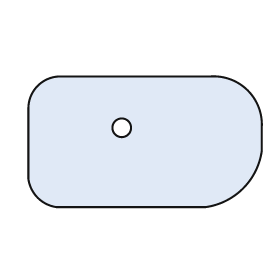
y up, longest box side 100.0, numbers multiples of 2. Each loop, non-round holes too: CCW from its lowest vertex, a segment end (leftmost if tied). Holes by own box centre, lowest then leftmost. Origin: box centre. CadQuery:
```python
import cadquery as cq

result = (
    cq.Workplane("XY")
    .moveTo(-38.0, -28.0)
    .lineTo(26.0, -28.0)
    .threePointArc((42.0, -20.0), (50.0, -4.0))
    .lineTo(50.0, 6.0)
    .threePointArc((44.0, 22.0), (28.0, 28.0))
    .lineTo(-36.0, 28.0)
    .threePointArc((-46.0, 24.0), (-50.0, 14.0))
    .lineTo(-50.0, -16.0)
    .threePointArc((-46.0, -24.0), (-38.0, -28.0))
    .close()
    .moveTo(-10.0, 6.0)
    .circle(4.0)
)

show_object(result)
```